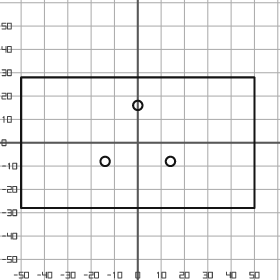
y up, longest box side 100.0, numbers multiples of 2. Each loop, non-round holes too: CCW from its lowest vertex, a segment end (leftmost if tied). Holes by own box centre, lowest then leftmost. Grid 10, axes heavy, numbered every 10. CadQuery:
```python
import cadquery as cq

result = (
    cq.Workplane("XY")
    .moveTo(-50.0, -28.0)
    .lineTo(50.0, -28.0)
    .lineTo(50.0, 28.0)
    .lineTo(-50.0, 28.0)
    .close()
    .moveTo(-14.0, -8.0)
    .circle(2.0)
    .moveTo(14.0, -8.0)
    .circle(2.0)
    .moveTo(0.0, 16.0)
    .circle(2.0)
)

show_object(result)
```